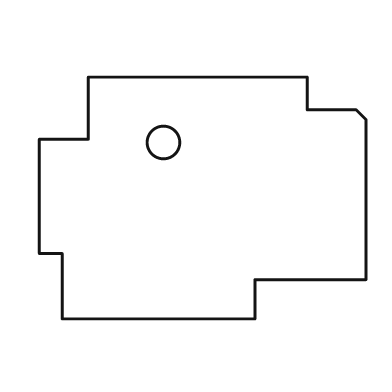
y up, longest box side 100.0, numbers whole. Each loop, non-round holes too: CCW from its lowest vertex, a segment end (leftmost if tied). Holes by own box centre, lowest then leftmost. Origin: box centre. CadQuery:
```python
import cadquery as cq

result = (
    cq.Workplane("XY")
    .moveTo(-43.0, -37.0)
    .lineTo(16.0, -37.0)
    .lineTo(16.0, -25.0)
    .lineTo(50.0, -25.0)
    .lineTo(50.0, 24.0)
    .lineTo(47.0, 27.0)
    .lineTo(32.0, 27.0)
    .lineTo(32.0, 37.0)
    .lineTo(-35.0, 37.0)
    .lineTo(-35.0, 18.0)
    .lineTo(-50.0, 18.0)
    .lineTo(-50.0, -17.0)
    .lineTo(-43.0, -17.0)
    .close()
    .moveTo(-12.0, 17.0)
    .circle(5.0)
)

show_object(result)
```